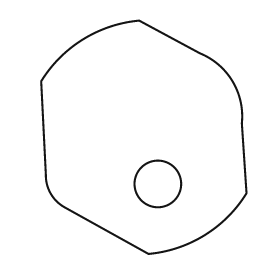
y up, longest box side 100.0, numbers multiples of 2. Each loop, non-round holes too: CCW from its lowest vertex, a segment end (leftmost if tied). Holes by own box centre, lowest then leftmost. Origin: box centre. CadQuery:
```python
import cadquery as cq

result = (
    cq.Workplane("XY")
    .moveTo(2.0, -50.0)
    .threePointArc((26.0, -42.0), (44.0, -24.0))
    .lineTo(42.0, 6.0)
    .threePointArc((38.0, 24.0), (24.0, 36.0))
    .lineTo(-2.0, 50.0)
    .threePointArc((-26.0, 42.0), (-44.0, 24.0))
    .lineTo(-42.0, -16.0)
    .threePointArc((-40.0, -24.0), (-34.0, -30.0))
    .close()
    .moveTo(6.0, -20.0)
    .circle(10.0)
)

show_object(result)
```